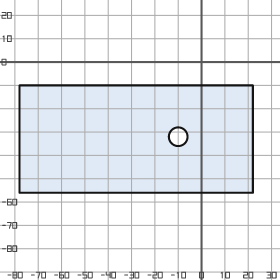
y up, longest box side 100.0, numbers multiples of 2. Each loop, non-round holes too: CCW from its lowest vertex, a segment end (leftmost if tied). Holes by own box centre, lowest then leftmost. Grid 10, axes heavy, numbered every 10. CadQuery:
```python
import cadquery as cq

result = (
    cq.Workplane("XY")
    .moveTo(-78.0, -56.0)
    .lineTo(22.0, -56.0)
    .lineTo(22.0, -10.0)
    .lineTo(-78.0, -10.0)
    .close()
    .moveTo(-10.0, -32.0)
    .circle(4.0)
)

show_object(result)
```